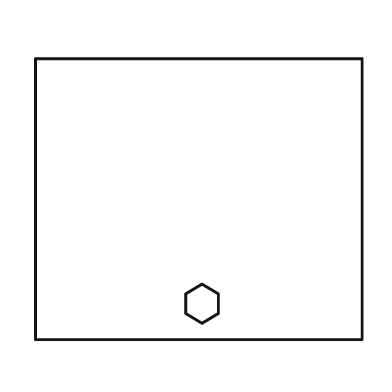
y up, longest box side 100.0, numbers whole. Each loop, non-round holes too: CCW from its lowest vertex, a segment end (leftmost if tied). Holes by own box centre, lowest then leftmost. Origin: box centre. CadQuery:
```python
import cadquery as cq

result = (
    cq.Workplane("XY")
    .moveTo(-50.0, -43.0)
    .lineTo(50.0, -43.0)
    .lineTo(50.0, 43.0)
    .lineTo(-50.0, 43.0)
    .close()
    .moveTo(1.0, -38.0)
    .lineTo(6.0, -35.0)
    .lineTo(6.0, -29.0)
    .lineTo(1.0, -26.0)
    .lineTo(-4.0, -29.0)
    .lineTo(-4.0, -35.0)
    .close()
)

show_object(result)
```